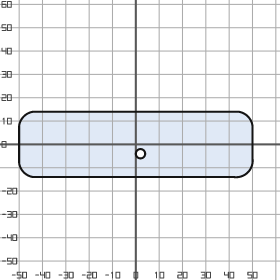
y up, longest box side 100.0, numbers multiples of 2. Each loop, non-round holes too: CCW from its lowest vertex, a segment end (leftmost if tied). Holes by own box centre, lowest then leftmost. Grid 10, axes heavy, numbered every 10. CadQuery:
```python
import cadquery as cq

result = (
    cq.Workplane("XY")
    .moveTo(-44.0, -14.0)
    .lineTo(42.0, -14.0)
    .threePointArc((48.0, -12.0), (50.0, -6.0))
    .lineTo(50.0, 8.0)
    .threePointArc((48.0, 12.0), (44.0, 14.0))
    .lineTo(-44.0, 14.0)
    .threePointArc((-48.0, 12.0), (-50.0, 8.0))
    .lineTo(-50.0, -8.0)
    .threePointArc((-48.0, -12.0), (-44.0, -14.0))
    .close()
    .moveTo(2.0, -4.0)
    .circle(2.0)
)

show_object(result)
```